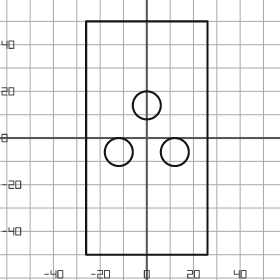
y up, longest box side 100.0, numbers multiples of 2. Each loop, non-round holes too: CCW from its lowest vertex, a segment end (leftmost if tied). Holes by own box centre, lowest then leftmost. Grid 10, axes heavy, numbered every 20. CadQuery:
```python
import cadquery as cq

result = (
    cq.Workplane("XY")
    .moveTo(-26.0, -50.0)
    .lineTo(26.0, -50.0)
    .lineTo(26.0, 50.0)
    .lineTo(-26.0, 50.0)
    .close()
    .moveTo(-12.0, -6.0)
    .circle(6.0)
    .moveTo(12.0, -6.0)
    .circle(6.0)
    .moveTo(0.0, 14.0)
    .circle(6.0)
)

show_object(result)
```